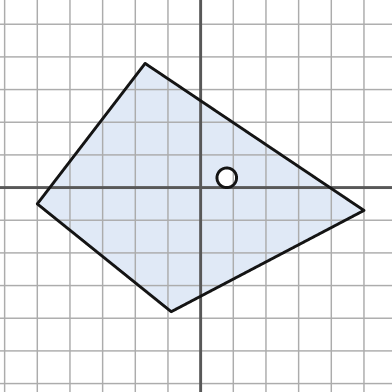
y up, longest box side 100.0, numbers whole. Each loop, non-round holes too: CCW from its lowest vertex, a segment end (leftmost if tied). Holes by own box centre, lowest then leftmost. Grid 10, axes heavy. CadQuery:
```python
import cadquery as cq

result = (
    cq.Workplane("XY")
    .moveTo(-9.0, -38.0)
    .lineTo(50.0, -7.0)
    .lineTo(-17.0, 38.0)
    .lineTo(-50.0, -5.0)
    .close()
    .moveTo(8.0, 3.0)
    .circle(3.0)
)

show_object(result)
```